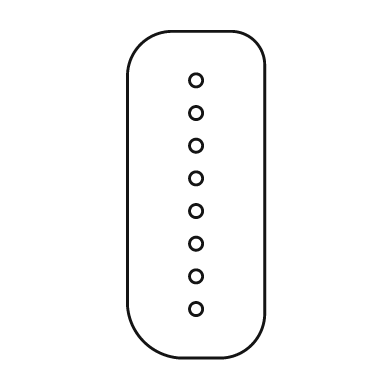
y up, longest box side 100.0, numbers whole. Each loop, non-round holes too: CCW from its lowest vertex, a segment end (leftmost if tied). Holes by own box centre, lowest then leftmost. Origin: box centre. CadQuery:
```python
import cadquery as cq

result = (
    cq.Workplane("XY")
    .moveTo(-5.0, -50.0)
    .lineTo(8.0, -50.0)
    .threePointArc((17.0, -46.0), (21.0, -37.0))
    .lineTo(21.0, 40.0)
    .threePointArc((18.0, 47.0), (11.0, 50.0))
    .lineTo(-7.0, 50.0)
    .threePointArc((-17.0, 46.0), (-21.0, 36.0))
    .lineTo(-21.0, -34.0)
    .threePointArc((-16.0, -45.0), (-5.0, -50.0))
    .close()
    .moveTo(0.0, -35.0)
    .circle(2.0)
    .moveTo(0.0, -25.0)
    .circle(2.0)
    .moveTo(0.0, -15.0)
    .circle(2.0)
    .moveTo(0.0, -5.0)
    .circle(2.0)
    .moveTo(0.0, 5.0)
    .circle(2.0)
    .moveTo(0.0, 15.0)
    .circle(2.0)
    .moveTo(0.0, 25.0)
    .circle(2.0)
    .moveTo(0.0, 35.0)
    .circle(2.0)
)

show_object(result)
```